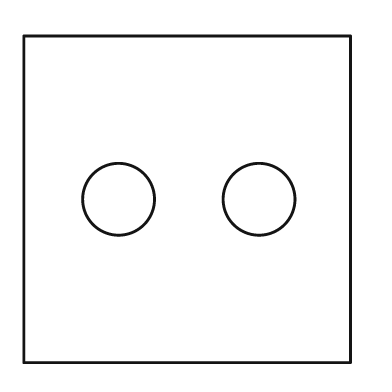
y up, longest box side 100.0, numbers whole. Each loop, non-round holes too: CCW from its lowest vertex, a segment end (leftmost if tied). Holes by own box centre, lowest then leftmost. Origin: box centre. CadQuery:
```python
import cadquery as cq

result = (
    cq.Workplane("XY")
    .moveTo(-50.0, -50.0)
    .lineTo(50.0, -50.0)
    .lineTo(50.0, 50.0)
    .lineTo(-50.0, 50.0)
    .close()
    .moveTo(-21.0, 0.0)
    .circle(11.0)
    .moveTo(22.0, 0.0)
    .circle(11.0)
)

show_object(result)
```